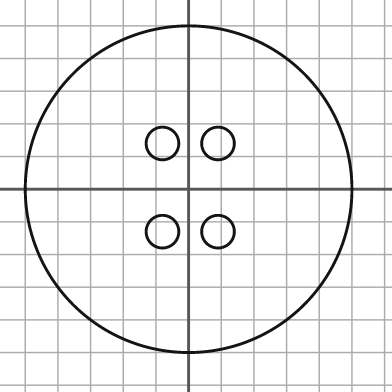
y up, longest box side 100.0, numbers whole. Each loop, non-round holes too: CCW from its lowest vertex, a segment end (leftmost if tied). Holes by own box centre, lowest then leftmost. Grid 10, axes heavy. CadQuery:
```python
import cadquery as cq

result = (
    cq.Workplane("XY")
    .moveTo(0.0, 0.0)
    .circle(50.0)
    .moveTo(-8.0, -13.0)
    .circle(5.0)
    .moveTo(9.0, -13.0)
    .circle(5.0)
    .moveTo(-8.0, 14.0)
    .circle(5.0)
    .moveTo(9.0, 14.0)
    .circle(5.0)
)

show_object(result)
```